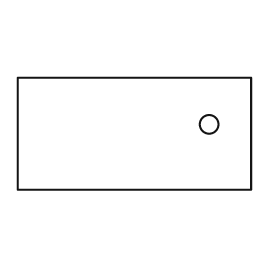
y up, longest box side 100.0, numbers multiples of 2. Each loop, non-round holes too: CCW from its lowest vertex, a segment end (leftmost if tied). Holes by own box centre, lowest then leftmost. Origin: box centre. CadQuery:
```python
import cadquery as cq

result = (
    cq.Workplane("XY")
    .moveTo(-50.0, -24.0)
    .lineTo(50.0, -24.0)
    .lineTo(50.0, 24.0)
    .lineTo(-50.0, 24.0)
    .close()
    .moveTo(32.0, 4.0)
    .circle(4.0)
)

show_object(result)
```